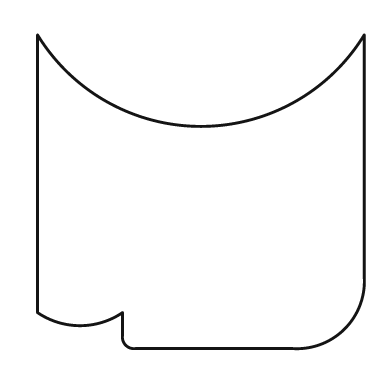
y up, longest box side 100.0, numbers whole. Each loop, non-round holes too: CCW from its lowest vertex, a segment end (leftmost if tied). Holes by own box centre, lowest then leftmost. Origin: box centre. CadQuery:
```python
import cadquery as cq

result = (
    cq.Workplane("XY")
    .moveTo(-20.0, -48.0)
    .lineTo(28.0, -48.0)
    .threePointArc((44.0, -42.0), (50.0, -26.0))
    .lineTo(50.0, 48.0)
    .threePointArc((0.0, 20.0), (-50.0, 48.0))
    .lineTo(-50.0, -37.0)
    .threePointArc((-37.0, -41.0), (-24.0, -37.0))
    .lineTo(-24.0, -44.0)
    .threePointArc((-23.0, -47.0), (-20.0, -48.0))
    .close()
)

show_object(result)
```